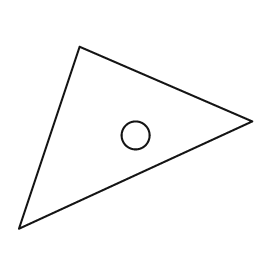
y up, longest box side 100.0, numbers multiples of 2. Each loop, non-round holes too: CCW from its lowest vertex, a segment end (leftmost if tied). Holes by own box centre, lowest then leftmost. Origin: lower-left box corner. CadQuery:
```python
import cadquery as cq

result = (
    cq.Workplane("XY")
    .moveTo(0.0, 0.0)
    .lineTo(100.0, 46.0)
    .lineTo(26.0, 78.0)
    .close()
    .moveTo(50.0, 40.0)
    .circle(6.0)
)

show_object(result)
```